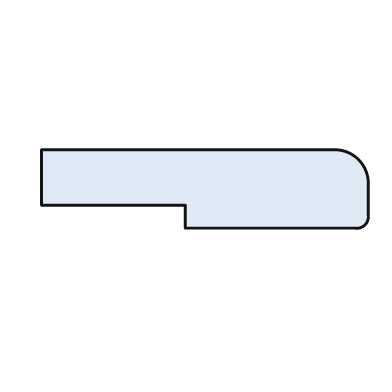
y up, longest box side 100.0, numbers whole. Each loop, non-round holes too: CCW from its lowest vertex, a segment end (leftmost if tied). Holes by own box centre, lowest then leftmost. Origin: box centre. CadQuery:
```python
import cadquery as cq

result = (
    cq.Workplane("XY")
    .moveTo(-6.0, -12.0)
    .lineTo(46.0, -12.0)
    .threePointArc((49.0, -11.0), (50.0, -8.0))
    .lineTo(50.0, 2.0)
    .threePointArc((47.0, 9.0), (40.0, 12.0))
    .lineTo(-50.0, 12.0)
    .lineTo(-50.0, -5.0)
    .lineTo(-6.0, -5.0)
    .close()
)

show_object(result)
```